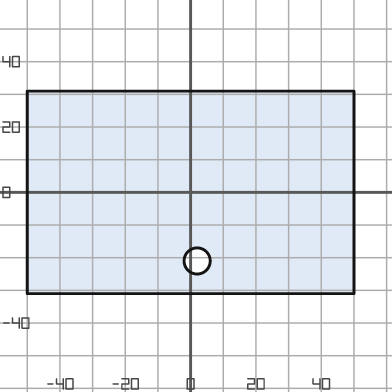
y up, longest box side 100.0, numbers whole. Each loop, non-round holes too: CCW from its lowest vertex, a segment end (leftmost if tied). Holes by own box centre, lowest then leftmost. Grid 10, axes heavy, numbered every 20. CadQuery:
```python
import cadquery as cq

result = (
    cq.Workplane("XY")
    .moveTo(-50.0, -31.0)
    .lineTo(50.0, -31.0)
    .lineTo(50.0, 31.0)
    .lineTo(-50.0, 31.0)
    .close()
    .moveTo(2.0, -21.0)
    .circle(4.0)
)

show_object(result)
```